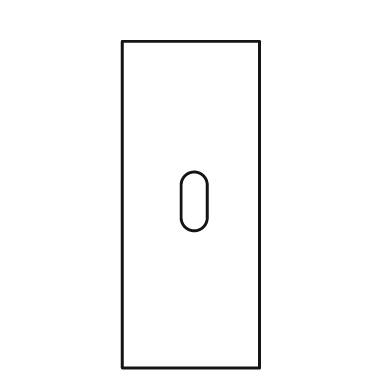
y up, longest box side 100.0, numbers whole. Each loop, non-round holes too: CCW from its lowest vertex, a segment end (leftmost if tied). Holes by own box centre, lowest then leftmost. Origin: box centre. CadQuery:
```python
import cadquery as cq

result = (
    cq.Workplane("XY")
    .moveTo(-21.0, -50.0)
    .lineTo(21.0, -50.0)
    .lineTo(21.0, 50.0)
    .lineTo(-21.0, 50.0)
    .close()
    .moveTo(-3.0, -4.0)
    .threePointArc((1.0, -8.0), (5.0, -4.0))
    .lineTo(5.0, 6.0)
    .threePointArc((1.0, 10.0), (-3.0, 6.0))
    .close()
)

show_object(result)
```